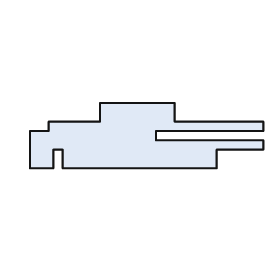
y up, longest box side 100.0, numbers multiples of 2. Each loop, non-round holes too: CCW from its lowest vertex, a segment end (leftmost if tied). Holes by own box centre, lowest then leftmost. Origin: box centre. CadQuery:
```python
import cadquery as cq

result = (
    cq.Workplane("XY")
    .moveTo(-50.0, -14.0)
    .lineTo(-40.0, -14.0)
    .lineTo(-40.0, -6.0)
    .lineTo(-36.0, -6.0)
    .lineTo(-36.0, -14.0)
    .lineTo(30.0, -14.0)
    .lineTo(30.0, -6.0)
    .lineTo(50.0, -6.0)
    .lineTo(50.0, -2.0)
    .lineTo(4.0, -2.0)
    .lineTo(4.0, 2.0)
    .lineTo(50.0, 2.0)
    .lineTo(50.0, 6.0)
    .lineTo(12.0, 6.0)
    .lineTo(12.0, 14.0)
    .lineTo(-20.0, 14.0)
    .lineTo(-20.0, 6.0)
    .lineTo(-42.0, 6.0)
    .lineTo(-42.0, 2.0)
    .lineTo(-50.0, 2.0)
    .close()
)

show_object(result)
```